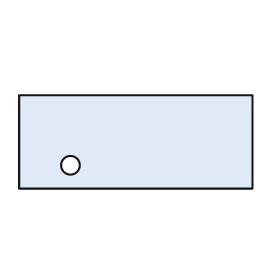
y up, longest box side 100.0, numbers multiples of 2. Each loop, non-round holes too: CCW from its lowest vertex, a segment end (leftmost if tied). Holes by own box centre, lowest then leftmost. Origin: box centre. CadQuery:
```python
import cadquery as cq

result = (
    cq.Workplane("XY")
    .moveTo(-50.0, -20.0)
    .lineTo(50.0, -20.0)
    .lineTo(50.0, 20.0)
    .lineTo(-50.0, 20.0)
    .close()
    .moveTo(-28.0, -10.0)
    .circle(4.0)
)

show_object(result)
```